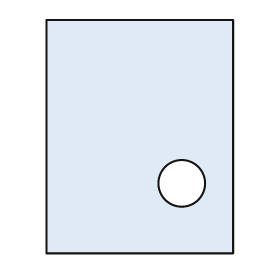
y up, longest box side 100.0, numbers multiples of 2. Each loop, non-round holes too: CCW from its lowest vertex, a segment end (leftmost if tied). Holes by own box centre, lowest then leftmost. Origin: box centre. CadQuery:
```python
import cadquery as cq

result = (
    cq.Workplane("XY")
    .moveTo(-40.0, -50.0)
    .lineTo(40.0, -50.0)
    .lineTo(40.0, 50.0)
    .lineTo(-40.0, 50.0)
    .close()
    .moveTo(18.0, -20.0)
    .circle(10.0)
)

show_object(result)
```